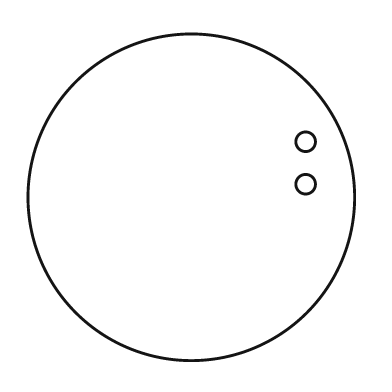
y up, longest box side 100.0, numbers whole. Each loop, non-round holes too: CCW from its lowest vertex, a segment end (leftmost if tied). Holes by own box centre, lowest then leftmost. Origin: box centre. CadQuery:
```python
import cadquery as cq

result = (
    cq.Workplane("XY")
    .moveTo(0.0, 0.0)
    .circle(50.0)
    .moveTo(35.0, 4.0)
    .circle(3.0)
    .moveTo(35.0, 17.0)
    .circle(3.0)
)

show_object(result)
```